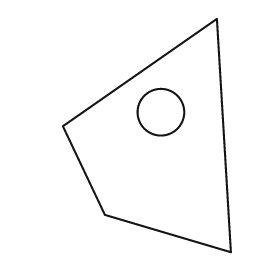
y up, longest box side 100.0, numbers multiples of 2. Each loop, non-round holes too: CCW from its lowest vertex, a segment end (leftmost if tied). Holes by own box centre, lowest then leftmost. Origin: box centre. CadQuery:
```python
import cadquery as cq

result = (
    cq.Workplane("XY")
    .moveTo(36.0, -50.0)
    .lineTo(30.0, 50.0)
    .lineTo(-36.0, 4.0)
    .lineTo(-18.0, -34.0)
    .close()
    .moveTo(6.0, 10.0)
    .circle(10.0)
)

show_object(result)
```